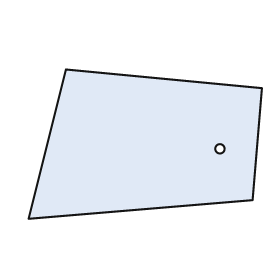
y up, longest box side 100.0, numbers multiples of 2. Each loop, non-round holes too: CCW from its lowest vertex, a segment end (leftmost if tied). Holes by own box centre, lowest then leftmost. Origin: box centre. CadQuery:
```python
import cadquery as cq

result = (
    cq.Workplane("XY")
    .moveTo(-50.0, -32.0)
    .lineTo(46.0, -24.0)
    .lineTo(50.0, 24.0)
    .lineTo(-34.0, 32.0)
    .close()
    .moveTo(32.0, -2.0)
    .circle(2.0)
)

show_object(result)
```